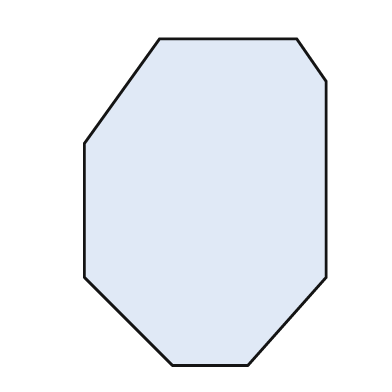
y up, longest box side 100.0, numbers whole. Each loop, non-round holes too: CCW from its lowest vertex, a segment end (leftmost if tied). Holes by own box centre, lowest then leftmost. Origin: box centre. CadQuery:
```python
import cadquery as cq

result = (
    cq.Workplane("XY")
    .moveTo(-10.0, -50.0)
    .lineTo(13.0, -50.0)
    .lineTo(37.0, -23.0)
    .lineTo(37.0, 37.0)
    .lineTo(28.0, 50.0)
    .lineTo(-14.0, 50.0)
    .lineTo(-37.0, 18.0)
    .lineTo(-37.0, -23.0)
    .close()
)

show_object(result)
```